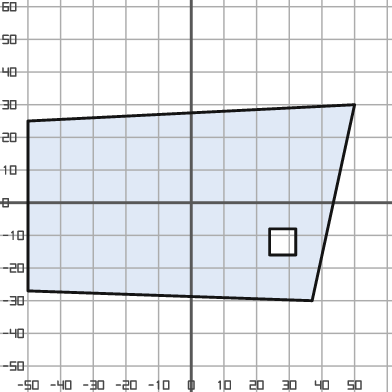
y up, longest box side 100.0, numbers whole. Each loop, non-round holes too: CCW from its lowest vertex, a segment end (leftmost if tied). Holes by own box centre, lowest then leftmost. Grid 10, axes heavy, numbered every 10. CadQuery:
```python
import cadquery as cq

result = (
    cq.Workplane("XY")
    .moveTo(37.0, -30.0)
    .lineTo(50.0, 30.0)
    .lineTo(-50.0, 25.0)
    .lineTo(-50.0, -27.0)
    .close()
    .moveTo(24.0, -16.0)
    .lineTo(32.0, -16.0)
    .lineTo(32.0, -8.0)
    .lineTo(24.0, -8.0)
    .close()
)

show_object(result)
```